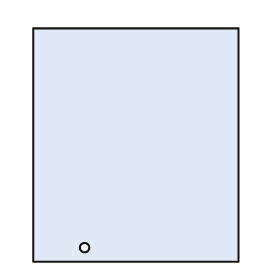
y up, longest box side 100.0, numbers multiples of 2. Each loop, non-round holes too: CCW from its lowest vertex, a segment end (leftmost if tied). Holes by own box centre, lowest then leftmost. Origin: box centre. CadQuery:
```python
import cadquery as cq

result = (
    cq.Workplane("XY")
    .moveTo(-44.0, -50.0)
    .lineTo(44.0, -50.0)
    .lineTo(44.0, 50.0)
    .lineTo(-44.0, 50.0)
    .close()
    .moveTo(-22.0, -44.0)
    .circle(2.0)
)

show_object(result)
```